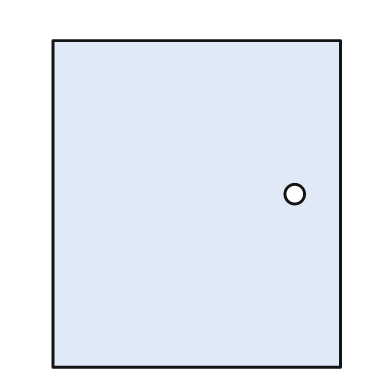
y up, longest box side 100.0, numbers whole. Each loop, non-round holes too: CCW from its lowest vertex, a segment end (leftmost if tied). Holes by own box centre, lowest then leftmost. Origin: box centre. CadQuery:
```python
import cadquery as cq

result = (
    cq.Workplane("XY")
    .moveTo(-44.0, -50.0)
    .lineTo(44.0, -50.0)
    .lineTo(44.0, 50.0)
    .lineTo(-44.0, 50.0)
    .close()
    .moveTo(30.0, 3.0)
    .circle(3.0)
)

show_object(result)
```